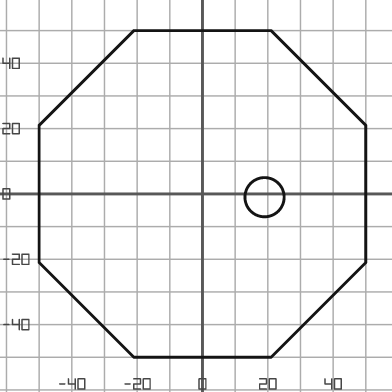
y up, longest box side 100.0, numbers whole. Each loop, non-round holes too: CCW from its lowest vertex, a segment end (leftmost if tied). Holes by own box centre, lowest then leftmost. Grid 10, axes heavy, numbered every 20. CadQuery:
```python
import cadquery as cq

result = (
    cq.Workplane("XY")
    .moveTo(-21.0, -50.0)
    .lineTo(21.0, -50.0)
    .lineTo(50.0, -21.0)
    .lineTo(50.0, 21.0)
    .lineTo(21.0, 50.0)
    .lineTo(-21.0, 50.0)
    .lineTo(-50.0, 21.0)
    .lineTo(-50.0, -21.0)
    .close()
    .moveTo(19.0, -1.0)
    .circle(6.0)
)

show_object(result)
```